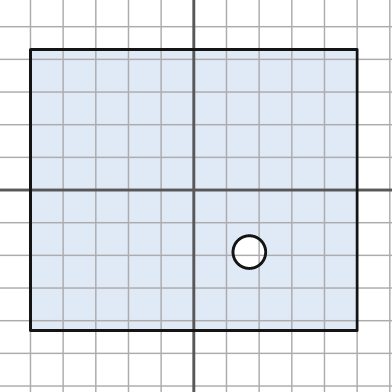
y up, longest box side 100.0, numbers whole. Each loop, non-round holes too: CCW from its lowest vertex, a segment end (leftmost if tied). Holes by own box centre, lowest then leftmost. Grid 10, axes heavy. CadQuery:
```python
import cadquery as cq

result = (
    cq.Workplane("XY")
    .moveTo(-50.0, -43.0)
    .lineTo(50.0, -43.0)
    .lineTo(50.0, 43.0)
    .lineTo(-50.0, 43.0)
    .close()
    .moveTo(17.0, -19.0)
    .circle(5.0)
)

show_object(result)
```